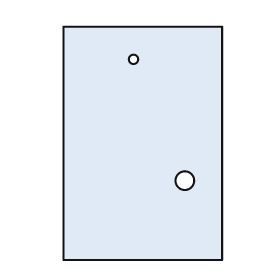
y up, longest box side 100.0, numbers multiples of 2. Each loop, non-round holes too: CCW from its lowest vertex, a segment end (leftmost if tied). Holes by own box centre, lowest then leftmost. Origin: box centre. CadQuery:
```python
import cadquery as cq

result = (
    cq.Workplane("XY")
    .moveTo(-34.0, -50.0)
    .lineTo(34.0, -50.0)
    .lineTo(34.0, 50.0)
    .lineTo(-34.0, 50.0)
    .close()
    .moveTo(18.0, -16.0)
    .circle(4.0)
    .moveTo(-4.0, 36.0)
    .circle(2.0)
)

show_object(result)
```